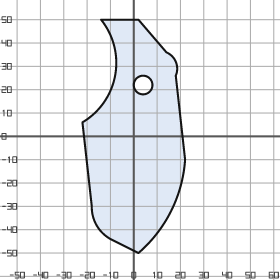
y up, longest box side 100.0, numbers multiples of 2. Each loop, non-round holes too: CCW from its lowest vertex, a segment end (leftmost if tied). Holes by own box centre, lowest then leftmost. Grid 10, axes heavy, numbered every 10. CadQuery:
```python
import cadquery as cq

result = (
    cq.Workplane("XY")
    .moveTo(2.0, -50.0)
    .threePointArc((16.0, -32.0), (22.0, -10.0))
    .lineTo(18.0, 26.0)
    .threePointArc((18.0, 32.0), (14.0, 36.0))
    .lineTo(2.0, 50.0)
    .lineTo(-14.0, 50.0)
    .threePointArc((-8.0, 26.0), (-22.0, 6.0))
    .lineTo(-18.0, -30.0)
    .threePointArc((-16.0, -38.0), (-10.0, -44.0))
    .close()
    .moveTo(4.0, 22.0)
    .circle(4.0)
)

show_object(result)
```